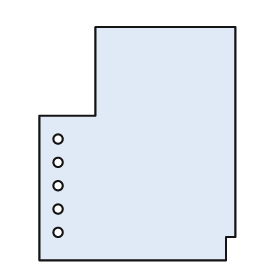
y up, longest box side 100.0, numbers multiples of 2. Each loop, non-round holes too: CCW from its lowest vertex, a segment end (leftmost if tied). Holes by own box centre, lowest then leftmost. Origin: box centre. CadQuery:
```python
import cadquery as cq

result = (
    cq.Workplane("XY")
    .moveTo(-42.0, -50.0)
    .lineTo(38.0, -50.0)
    .lineTo(38.0, -40.0)
    .lineTo(42.0, -40.0)
    .lineTo(42.0, 50.0)
    .lineTo(-18.0, 50.0)
    .lineTo(-18.0, 12.0)
    .lineTo(-42.0, 12.0)
    .close()
    .moveTo(-34.0, -38.0)
    .circle(2.0)
    .moveTo(-34.0, -28.0)
    .circle(2.0)
    .moveTo(-34.0, -18.0)
    .circle(2.0)
    .moveTo(-34.0, -8.0)
    .circle(2.0)
    .moveTo(-34.0, 2.0)
    .circle(2.0)
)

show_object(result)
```